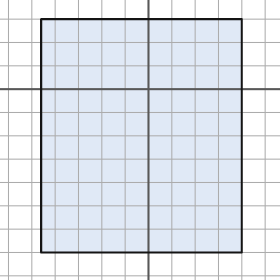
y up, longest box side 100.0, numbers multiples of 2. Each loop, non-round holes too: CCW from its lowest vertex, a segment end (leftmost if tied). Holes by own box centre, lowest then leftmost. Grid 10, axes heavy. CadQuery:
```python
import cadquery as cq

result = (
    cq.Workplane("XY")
    .moveTo(-46.0, -70.0)
    .lineTo(40.0, -70.0)
    .lineTo(40.0, 30.0)
    .lineTo(-46.0, 30.0)
    .close()
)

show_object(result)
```